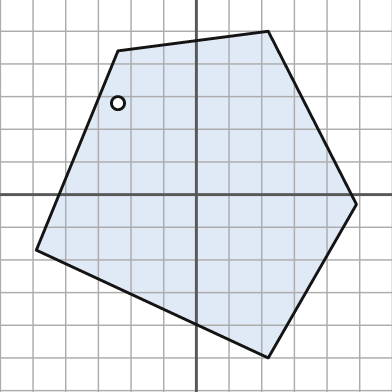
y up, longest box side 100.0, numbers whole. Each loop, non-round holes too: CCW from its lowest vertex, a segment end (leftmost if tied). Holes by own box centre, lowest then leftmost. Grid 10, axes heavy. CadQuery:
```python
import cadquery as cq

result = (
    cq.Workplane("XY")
    .moveTo(22.0, -50.0)
    .lineTo(49.0, -3.0)
    .lineTo(22.0, 50.0)
    .lineTo(-24.0, 44.0)
    .lineTo(-49.0, -17.0)
    .close()
    .moveTo(-24.0, 28.0)
    .circle(2.0)
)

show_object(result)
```